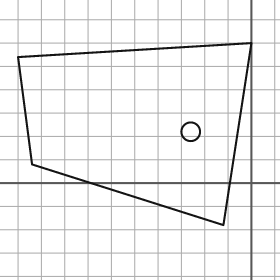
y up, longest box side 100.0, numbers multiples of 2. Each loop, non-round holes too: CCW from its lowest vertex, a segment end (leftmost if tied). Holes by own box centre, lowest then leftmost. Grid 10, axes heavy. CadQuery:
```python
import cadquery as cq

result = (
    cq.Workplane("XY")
    .moveTo(-12.0, -18.0)
    .lineTo(0.0, 60.0)
    .lineTo(-100.0, 54.0)
    .lineTo(-94.0, 8.0)
    .close()
    .moveTo(-26.0, 22.0)
    .circle(4.0)
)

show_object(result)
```